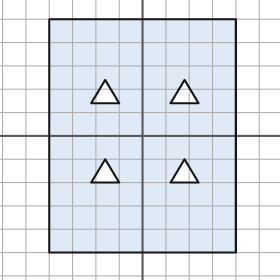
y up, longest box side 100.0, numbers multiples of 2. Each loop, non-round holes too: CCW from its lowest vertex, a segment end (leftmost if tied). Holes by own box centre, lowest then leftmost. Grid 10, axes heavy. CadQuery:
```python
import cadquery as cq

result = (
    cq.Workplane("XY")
    .moveTo(-40.0, -50.0)
    .lineTo(40.0, -50.0)
    .lineTo(40.0, 50.0)
    .lineTo(-40.0, 50.0)
    .close()
    .moveTo(-22.0, -20.0)
    .lineTo(-10.0, -20.0)
    .lineTo(-16.0, -10.0)
    .close()
    .moveTo(12.0, -20.0)
    .lineTo(24.0, -20.0)
    .lineTo(18.0, -10.0)
    .close()
    .moveTo(-22.0, 14.0)
    .lineTo(-10.0, 14.0)
    .lineTo(-16.0, 24.0)
    .close()
    .moveTo(12.0, 14.0)
    .lineTo(24.0, 14.0)
    .lineTo(18.0, 24.0)
    .close()
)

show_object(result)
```